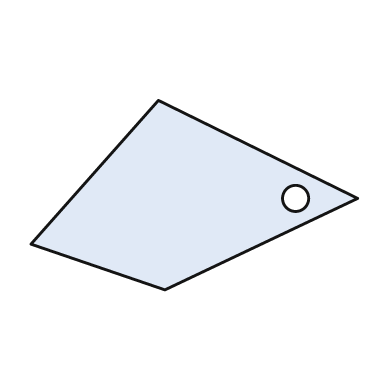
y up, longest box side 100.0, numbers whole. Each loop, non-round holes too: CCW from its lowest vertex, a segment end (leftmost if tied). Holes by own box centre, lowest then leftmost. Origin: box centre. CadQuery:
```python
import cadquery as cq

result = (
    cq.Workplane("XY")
    .moveTo(-9.0, -29.0)
    .lineTo(50.0, -1.0)
    .lineTo(-11.0, 29.0)
    .lineTo(-50.0, -15.0)
    .close()
    .moveTo(31.0, -1.0)
    .circle(4.0)
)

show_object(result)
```